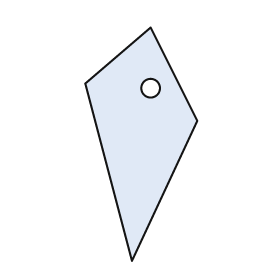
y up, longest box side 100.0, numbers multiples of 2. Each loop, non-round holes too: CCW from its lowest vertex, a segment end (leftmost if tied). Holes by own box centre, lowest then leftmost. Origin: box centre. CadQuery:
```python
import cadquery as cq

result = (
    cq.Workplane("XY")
    .moveTo(-4.0, -50.0)
    .lineTo(24.0, 10.0)
    .lineTo(4.0, 50.0)
    .lineTo(-24.0, 26.0)
    .close()
    .moveTo(4.0, 24.0)
    .circle(4.0)
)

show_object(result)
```